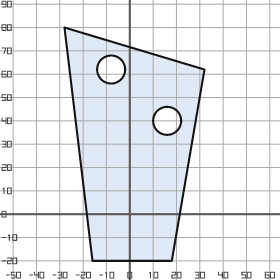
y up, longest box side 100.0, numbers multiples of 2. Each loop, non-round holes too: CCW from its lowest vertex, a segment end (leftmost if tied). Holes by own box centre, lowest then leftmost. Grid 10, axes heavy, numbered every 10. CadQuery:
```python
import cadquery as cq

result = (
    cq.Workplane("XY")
    .moveTo(-16.0, -20.0)
    .lineTo(18.0, -20.0)
    .lineTo(32.0, 62.0)
    .lineTo(-28.0, 80.0)
    .close()
    .moveTo(16.0, 40.0)
    .circle(6.0)
    .moveTo(-8.0, 62.0)
    .circle(6.0)
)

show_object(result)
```